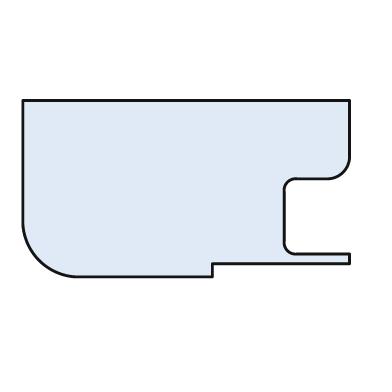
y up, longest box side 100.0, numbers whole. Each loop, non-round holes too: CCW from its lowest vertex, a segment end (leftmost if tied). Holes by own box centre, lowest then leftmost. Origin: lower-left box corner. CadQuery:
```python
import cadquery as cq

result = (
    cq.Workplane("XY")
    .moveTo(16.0, 0.0)
    .lineTo(58.0, 0.0)
    .lineTo(58.0, 4.0)
    .lineTo(100.0, 4.0)
    .lineTo(100.0, 7.0)
    .lineTo(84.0, 7.0)
    .threePointArc((81.0, 8.0), (80.0, 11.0))
    .lineTo(80.0, 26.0)
    .threePointArc((81.0, 29.0), (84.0, 30.0))
    .lineTo(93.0, 30.0)
    .threePointArc((98.0, 32.0), (100.0, 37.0))
    .lineTo(100.0, 54.0)
    .lineTo(0.0, 54.0)
    .lineTo(0.0, 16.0)
    .threePointArc((5.0, 5.0), (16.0, 0.0))
    .close()
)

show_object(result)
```